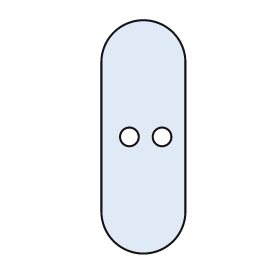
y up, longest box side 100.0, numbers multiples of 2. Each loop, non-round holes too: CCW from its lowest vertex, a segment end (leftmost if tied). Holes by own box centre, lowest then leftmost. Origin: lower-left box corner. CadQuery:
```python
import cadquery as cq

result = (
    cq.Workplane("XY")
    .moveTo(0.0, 18.0)
    .threePointArc((18.0, 0.0), (36.0, 18.0))
    .lineTo(36.0, 82.0)
    .threePointArc((18.0, 100.0), (0.0, 82.0))
    .close()
    .moveTo(12.0, 50.0)
    .circle(4.0)
    .moveTo(26.0, 50.0)
    .circle(4.0)
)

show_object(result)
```